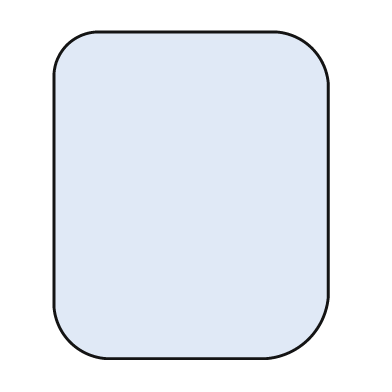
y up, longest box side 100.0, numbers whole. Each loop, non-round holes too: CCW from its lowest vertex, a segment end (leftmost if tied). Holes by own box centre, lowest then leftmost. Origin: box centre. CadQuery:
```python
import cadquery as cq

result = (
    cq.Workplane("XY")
    .moveTo(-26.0, -50.0)
    .lineTo(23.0, -50.0)
    .threePointArc((36.0, -44.0), (42.0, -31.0))
    .lineTo(42.0, 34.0)
    .threePointArc((37.0, 45.0), (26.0, 50.0))
    .lineTo(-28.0, 50.0)
    .threePointArc((-38.0, 46.0), (-42.0, 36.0))
    .lineTo(-42.0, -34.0)
    .threePointArc((-37.0, -45.0), (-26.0, -50.0))
    .close()
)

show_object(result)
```